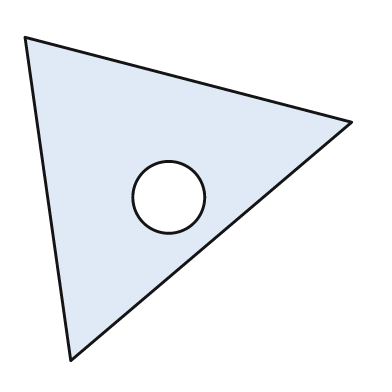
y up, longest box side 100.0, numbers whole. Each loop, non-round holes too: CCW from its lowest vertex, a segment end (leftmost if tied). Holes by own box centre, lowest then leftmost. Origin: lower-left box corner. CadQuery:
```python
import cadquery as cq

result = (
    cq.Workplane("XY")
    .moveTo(14.0, 0.0)
    .lineTo(100.0, 73.0)
    .lineTo(0.0, 99.0)
    .close()
    .moveTo(44.0, 50.0)
    .circle(11.0)
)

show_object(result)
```